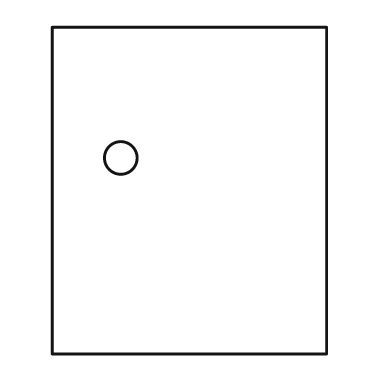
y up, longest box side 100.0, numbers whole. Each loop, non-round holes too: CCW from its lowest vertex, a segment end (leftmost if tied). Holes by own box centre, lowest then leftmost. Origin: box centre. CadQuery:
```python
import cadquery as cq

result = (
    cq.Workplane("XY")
    .moveTo(-42.0, -50.0)
    .lineTo(42.0, -50.0)
    .lineTo(42.0, 50.0)
    .lineTo(-42.0, 50.0)
    .close()
    .moveTo(-21.0, 10.0)
    .circle(5.0)
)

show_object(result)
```